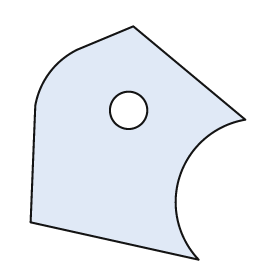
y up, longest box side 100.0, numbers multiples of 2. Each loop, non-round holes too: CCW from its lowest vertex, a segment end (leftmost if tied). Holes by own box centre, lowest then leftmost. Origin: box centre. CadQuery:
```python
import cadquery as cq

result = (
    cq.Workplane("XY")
    .moveTo(26.0, -50.0)
    .threePointArc((18.0, -14.0), (46.0, 10.0))
    .lineTo(-2.0, 50.0)
    .lineTo(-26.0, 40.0)
    .threePointArc((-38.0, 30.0), (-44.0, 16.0))
    .lineTo(-46.0, -34.0)
    .close()
    .moveTo(-4.0, 14.0)
    .circle(8.0)
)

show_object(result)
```